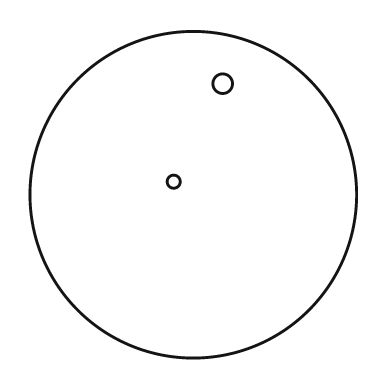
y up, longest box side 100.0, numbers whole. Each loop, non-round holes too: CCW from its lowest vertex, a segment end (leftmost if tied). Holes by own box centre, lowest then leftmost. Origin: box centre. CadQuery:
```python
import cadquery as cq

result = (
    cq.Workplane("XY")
    .moveTo(0.0, 0.0)
    .circle(50.0)
    .moveTo(-6.0, 4.0)
    .circle(2.0)
    .moveTo(9.0, 34.0)
    .circle(3.0)
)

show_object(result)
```